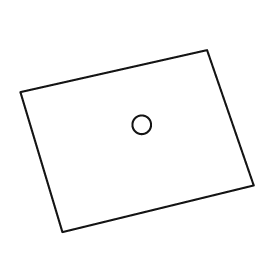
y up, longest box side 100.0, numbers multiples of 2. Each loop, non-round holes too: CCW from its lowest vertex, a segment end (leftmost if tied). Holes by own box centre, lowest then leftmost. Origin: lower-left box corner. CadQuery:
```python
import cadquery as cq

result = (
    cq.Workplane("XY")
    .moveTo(18.0, 0.0)
    .lineTo(100.0, 20.0)
    .lineTo(80.0, 78.0)
    .lineTo(0.0, 60.0)
    .close()
    .moveTo(52.0, 46.0)
    .circle(4.0)
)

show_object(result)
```